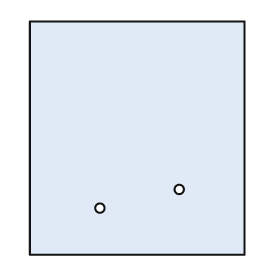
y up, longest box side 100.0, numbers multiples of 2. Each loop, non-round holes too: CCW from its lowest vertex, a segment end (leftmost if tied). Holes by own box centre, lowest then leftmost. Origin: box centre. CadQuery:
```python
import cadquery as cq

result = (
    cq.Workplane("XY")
    .moveTo(-46.0, -50.0)
    .lineTo(46.0, -50.0)
    .lineTo(46.0, 50.0)
    .lineTo(-46.0, 50.0)
    .close()
    .moveTo(-16.0, -30.0)
    .circle(2.0)
    .moveTo(18.0, -22.0)
    .circle(2.0)
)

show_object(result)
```